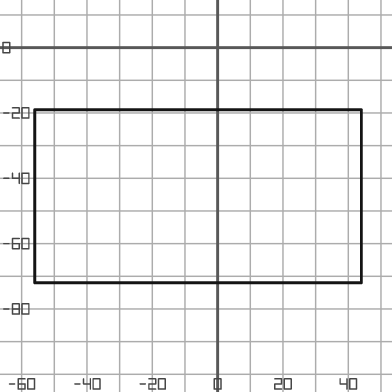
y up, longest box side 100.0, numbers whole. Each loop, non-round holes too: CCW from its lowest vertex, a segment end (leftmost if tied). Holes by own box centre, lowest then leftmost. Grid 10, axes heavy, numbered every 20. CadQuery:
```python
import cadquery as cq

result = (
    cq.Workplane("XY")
    .moveTo(-56.0, -72.0)
    .lineTo(44.0, -72.0)
    .lineTo(44.0, -19.0)
    .lineTo(-56.0, -19.0)
    .close()
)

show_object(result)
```